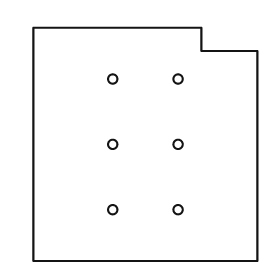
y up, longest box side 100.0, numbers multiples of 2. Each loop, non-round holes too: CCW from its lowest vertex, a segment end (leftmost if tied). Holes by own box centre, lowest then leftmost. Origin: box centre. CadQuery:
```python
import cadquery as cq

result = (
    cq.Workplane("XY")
    .moveTo(-48.0, -50.0)
    .lineTo(48.0, -50.0)
    .lineTo(48.0, 40.0)
    .lineTo(24.0, 40.0)
    .lineTo(24.0, 50.0)
    .lineTo(-48.0, 50.0)
    .close()
    .moveTo(-14.0, -28.0)
    .circle(2.0)
    .moveTo(14.0, -28.0)
    .circle(2.0)
    .moveTo(-14.0, 0.0)
    .circle(2.0)
    .moveTo(14.0, 0.0)
    .circle(2.0)
    .moveTo(-14.0, 28.0)
    .circle(2.0)
    .moveTo(14.0, 28.0)
    .circle(2.0)
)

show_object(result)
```